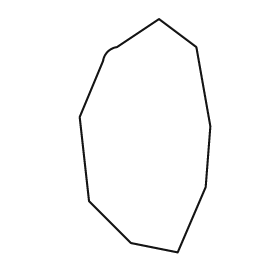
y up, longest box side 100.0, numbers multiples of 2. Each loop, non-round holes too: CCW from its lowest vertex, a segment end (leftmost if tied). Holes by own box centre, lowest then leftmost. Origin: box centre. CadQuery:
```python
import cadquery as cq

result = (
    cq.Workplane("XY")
    .moveTo(14.0, -50.0)
    .lineTo(26.0, -22.0)
    .lineTo(28.0, 4.0)
    .lineTo(22.0, 38.0)
    .lineTo(6.0, 50.0)
    .lineTo(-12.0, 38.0)
    .threePointArc((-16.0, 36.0), (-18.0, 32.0))
    .lineTo(-28.0, 8.0)
    .lineTo(-24.0, -28.0)
    .lineTo(-6.0, -46.0)
    .close()
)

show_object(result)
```